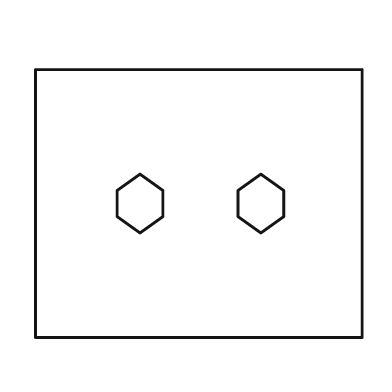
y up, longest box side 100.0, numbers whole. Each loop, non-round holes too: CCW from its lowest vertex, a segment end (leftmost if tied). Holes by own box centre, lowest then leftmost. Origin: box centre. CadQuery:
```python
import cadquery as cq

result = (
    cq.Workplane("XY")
    .moveTo(-50.0, -41.0)
    .lineTo(50.0, -41.0)
    .lineTo(50.0, 41.0)
    .lineTo(-50.0, 41.0)
    .close()
    .moveTo(-18.0, -9.0)
    .lineTo(-11.0, -4.0)
    .lineTo(-11.0, 4.0)
    .lineTo(-18.0, 9.0)
    .lineTo(-25.0, 4.0)
    .lineTo(-25.0, -4.0)
    .close()
    .moveTo(19.0, -9.0)
    .lineTo(26.0, -4.0)
    .lineTo(26.0, 4.0)
    .lineTo(19.0, 9.0)
    .lineTo(12.0, 4.0)
    .lineTo(12.0, -4.0)
    .close()
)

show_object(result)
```